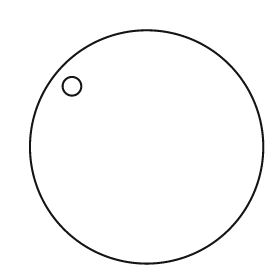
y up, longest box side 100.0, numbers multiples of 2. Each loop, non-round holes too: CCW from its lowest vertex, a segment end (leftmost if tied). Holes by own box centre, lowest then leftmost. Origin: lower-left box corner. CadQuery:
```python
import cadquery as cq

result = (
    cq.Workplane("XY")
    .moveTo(50.0, 50.0)
    .circle(50.0)
    .moveTo(18.0, 76.0)
    .circle(4.0)
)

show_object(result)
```